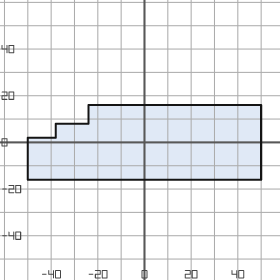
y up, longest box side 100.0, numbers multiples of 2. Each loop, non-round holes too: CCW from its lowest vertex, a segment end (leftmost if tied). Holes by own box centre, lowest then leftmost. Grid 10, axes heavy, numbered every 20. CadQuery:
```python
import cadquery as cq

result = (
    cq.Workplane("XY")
    .moveTo(-50.0, -16.0)
    .lineTo(50.0, -16.0)
    .lineTo(50.0, 16.0)
    .lineTo(-24.0, 16.0)
    .lineTo(-24.0, 8.0)
    .lineTo(-38.0, 8.0)
    .lineTo(-38.0, 2.0)
    .lineTo(-50.0, 2.0)
    .close()
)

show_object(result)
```